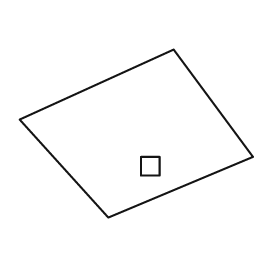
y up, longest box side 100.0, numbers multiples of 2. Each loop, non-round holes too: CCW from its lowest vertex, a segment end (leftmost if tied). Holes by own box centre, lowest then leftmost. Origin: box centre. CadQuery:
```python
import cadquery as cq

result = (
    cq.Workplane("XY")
    .moveTo(-12.0, -36.0)
    .lineTo(50.0, -10.0)
    .lineTo(16.0, 36.0)
    .lineTo(-50.0, 6.0)
    .close()
    .moveTo(2.0, -18.0)
    .lineTo(10.0, -18.0)
    .lineTo(10.0, -10.0)
    .lineTo(2.0, -10.0)
    .close()
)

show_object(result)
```